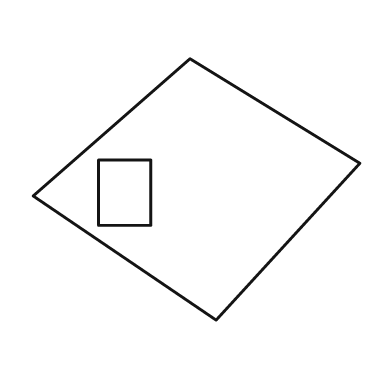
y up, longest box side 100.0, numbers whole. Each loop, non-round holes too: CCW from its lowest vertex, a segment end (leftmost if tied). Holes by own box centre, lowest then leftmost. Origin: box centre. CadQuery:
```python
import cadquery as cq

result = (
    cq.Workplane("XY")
    .moveTo(6.0, -40.0)
    .lineTo(50.0, 8.0)
    .lineTo(-2.0, 40.0)
    .lineTo(-50.0, -2.0)
    .close()
    .moveTo(-30.0, -11.0)
    .lineTo(-14.0, -11.0)
    .lineTo(-14.0, 9.0)
    .lineTo(-30.0, 9.0)
    .close()
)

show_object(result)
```